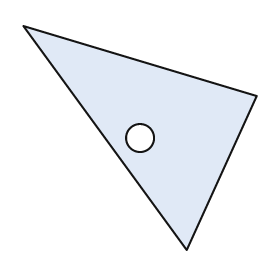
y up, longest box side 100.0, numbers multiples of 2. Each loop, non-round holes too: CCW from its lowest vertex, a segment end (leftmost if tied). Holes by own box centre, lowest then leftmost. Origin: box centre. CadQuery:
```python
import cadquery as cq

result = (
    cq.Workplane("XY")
    .moveTo(20.0, -48.0)
    .lineTo(50.0, 18.0)
    .lineTo(-50.0, 48.0)
    .close()
    .moveTo(0.0, 0.0)
    .circle(6.0)
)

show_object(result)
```